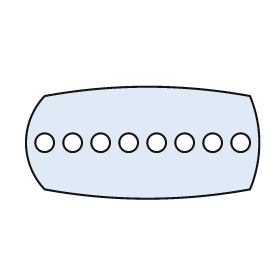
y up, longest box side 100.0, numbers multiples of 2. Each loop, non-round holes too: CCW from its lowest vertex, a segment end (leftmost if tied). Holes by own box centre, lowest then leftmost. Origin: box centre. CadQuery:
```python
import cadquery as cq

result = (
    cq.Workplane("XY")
    .moveTo(-42.0, -20.0)
    .threePointArc((2.0, -24.0), (46.0, -20.0))
    .threePointArc((50.0, 0.0), (46.0, 20.0))
    .threePointArc((2.0, 24.0), (-42.0, 20.0))
    .threePointArc((-50.0, 0.0), (-42.0, -20.0))
    .close()
    .moveTo(-42.0, 0.0)
    .circle(4.0)
    .moveTo(-30.0, 0.0)
    .circle(4.0)
    .moveTo(-18.0, 0.0)
    .circle(4.0)
    .moveTo(-6.0, 0.0)
    .circle(4.0)
    .moveTo(6.0, 0.0)
    .circle(4.0)
    .moveTo(18.0, 0.0)
    .circle(4.0)
    .moveTo(30.0, 0.0)
    .circle(4.0)
    .moveTo(42.0, 0.0)
    .circle(4.0)
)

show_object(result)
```